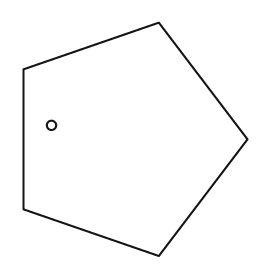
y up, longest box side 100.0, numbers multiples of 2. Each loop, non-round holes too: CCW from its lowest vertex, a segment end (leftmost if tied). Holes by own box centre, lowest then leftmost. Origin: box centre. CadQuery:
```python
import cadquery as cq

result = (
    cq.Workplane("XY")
    .moveTo(10.0, -50.0)
    .lineTo(48.0, 0.0)
    .lineTo(10.0, 50.0)
    .lineTo(-48.0, 30.0)
    .lineTo(-48.0, -30.0)
    .close()
    .moveTo(-36.0, 6.0)
    .circle(2.0)
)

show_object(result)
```